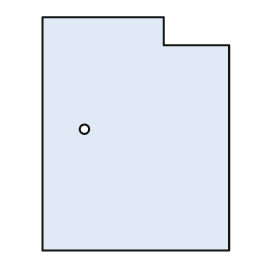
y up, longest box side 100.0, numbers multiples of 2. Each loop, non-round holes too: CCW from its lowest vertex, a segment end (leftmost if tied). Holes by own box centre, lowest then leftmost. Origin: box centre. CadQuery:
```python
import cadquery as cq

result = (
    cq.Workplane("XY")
    .moveTo(-40.0, -50.0)
    .lineTo(40.0, -50.0)
    .lineTo(40.0, 38.0)
    .lineTo(12.0, 38.0)
    .lineTo(12.0, 50.0)
    .lineTo(-40.0, 50.0)
    .close()
    .moveTo(-22.0, 2.0)
    .circle(2.0)
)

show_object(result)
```